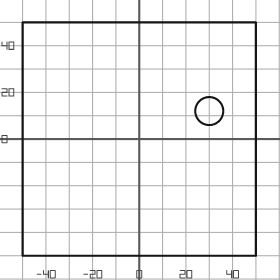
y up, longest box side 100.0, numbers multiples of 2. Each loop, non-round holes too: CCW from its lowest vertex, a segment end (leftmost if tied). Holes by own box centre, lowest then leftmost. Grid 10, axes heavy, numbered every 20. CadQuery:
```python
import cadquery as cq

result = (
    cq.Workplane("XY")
    .moveTo(-50.0, -50.0)
    .lineTo(50.0, -50.0)
    .lineTo(50.0, 50.0)
    .lineTo(-50.0, 50.0)
    .close()
    .moveTo(30.0, 12.0)
    .circle(6.0)
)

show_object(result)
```